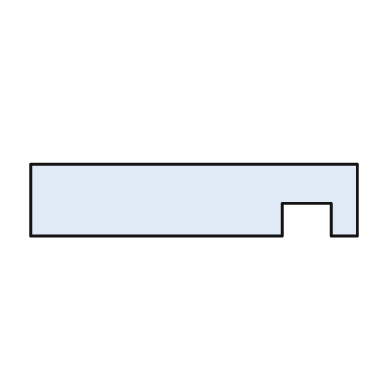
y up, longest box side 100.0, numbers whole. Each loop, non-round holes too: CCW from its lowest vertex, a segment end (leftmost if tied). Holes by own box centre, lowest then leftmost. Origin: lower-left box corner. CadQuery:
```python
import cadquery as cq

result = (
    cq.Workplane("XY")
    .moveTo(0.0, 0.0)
    .lineTo(77.0, 0.0)
    .lineTo(77.0, 10.0)
    .lineTo(92.0, 10.0)
    .lineTo(92.0, 0.0)
    .lineTo(100.0, 0.0)
    .lineTo(100.0, 22.0)
    .lineTo(0.0, 22.0)
    .close()
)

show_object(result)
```